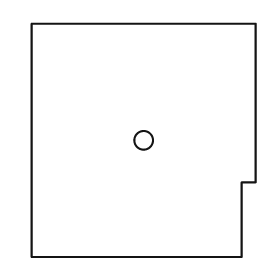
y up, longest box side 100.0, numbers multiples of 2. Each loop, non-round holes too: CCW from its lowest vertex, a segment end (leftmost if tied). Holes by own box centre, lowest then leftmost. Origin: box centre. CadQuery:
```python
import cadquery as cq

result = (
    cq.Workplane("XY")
    .moveTo(-48.0, -50.0)
    .lineTo(42.0, -50.0)
    .lineTo(42.0, -18.0)
    .lineTo(48.0, -18.0)
    .lineTo(48.0, 50.0)
    .lineTo(-48.0, 50.0)
    .close()
    .moveTo(0.0, 0.0)
    .circle(4.0)
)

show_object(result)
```